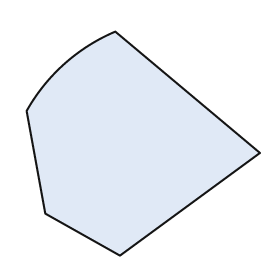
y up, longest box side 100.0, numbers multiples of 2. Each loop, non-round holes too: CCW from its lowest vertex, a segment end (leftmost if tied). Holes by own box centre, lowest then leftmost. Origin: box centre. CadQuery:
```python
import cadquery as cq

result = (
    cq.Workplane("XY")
    .moveTo(-10.0, -48.0)
    .lineTo(50.0, -4.0)
    .lineTo(-12.0, 48.0)
    .threePointArc((-34.0, 34.0), (-50.0, 14.0))
    .lineTo(-42.0, -30.0)
    .close()
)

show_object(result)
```